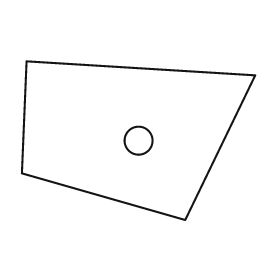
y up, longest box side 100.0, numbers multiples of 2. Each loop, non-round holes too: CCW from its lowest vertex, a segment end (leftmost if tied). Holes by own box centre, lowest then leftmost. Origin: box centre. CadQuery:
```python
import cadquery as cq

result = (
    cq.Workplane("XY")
    .moveTo(20.0, -34.0)
    .lineTo(50.0, 28.0)
    .lineTo(-48.0, 34.0)
    .lineTo(-50.0, -14.0)
    .close()
    .moveTo(0.0, 0.0)
    .circle(6.0)
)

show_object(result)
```